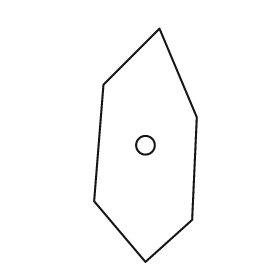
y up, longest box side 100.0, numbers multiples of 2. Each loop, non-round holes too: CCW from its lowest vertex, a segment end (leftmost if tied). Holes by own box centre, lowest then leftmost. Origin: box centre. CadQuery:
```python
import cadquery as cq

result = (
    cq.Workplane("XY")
    .moveTo(0.0, -50.0)
    .lineTo(20.0, -32.0)
    .lineTo(22.0, 12.0)
    .lineTo(6.0, 50.0)
    .lineTo(-18.0, 26.0)
    .lineTo(-22.0, -24.0)
    .close()
    .moveTo(0.0, 0.0)
    .circle(4.0)
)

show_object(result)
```